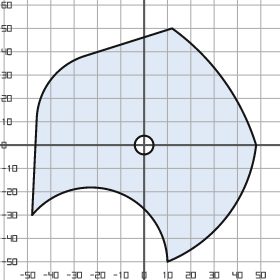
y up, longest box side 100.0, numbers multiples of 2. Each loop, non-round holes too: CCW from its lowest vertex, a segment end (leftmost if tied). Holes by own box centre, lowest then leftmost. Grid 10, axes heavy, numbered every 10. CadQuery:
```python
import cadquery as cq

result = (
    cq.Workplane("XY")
    .moveTo(10.0, -50.0)
    .threePointArc((36.0, -30.0), (48.0, 0.0))
    .threePointArc((34.0, 28.0), (12.0, 50.0))
    .lineTo(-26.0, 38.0)
    .threePointArc((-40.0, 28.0), (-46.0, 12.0))
    .lineTo(-48.0, -30.0)
    .threePointArc((-12.0, -20.0), (10.0, -50.0))
    .close()
    .moveTo(0.0, 0.0)
    .circle(4.0)
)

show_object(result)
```